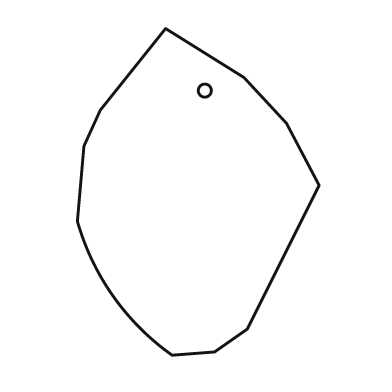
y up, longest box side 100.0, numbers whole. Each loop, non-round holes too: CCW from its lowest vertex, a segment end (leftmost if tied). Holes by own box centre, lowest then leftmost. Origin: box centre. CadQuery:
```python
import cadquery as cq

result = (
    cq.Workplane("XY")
    .moveTo(-8.0, -50.0)
    .lineTo(5.0, -49.0)
    .lineTo(15.0, -42.0)
    .lineTo(37.0, 2.0)
    .lineTo(27.0, 21.0)
    .lineTo(14.0, 35.0)
    .lineTo(-10.0, 50.0)
    .lineTo(-30.0, 25.0)
    .lineTo(-35.0, 14.0)
    .lineTo(-37.0, -9.0)
    .threePointArc((-26.0, -32.0), (-8.0, -50.0))
    .close()
    .moveTo(2.0, 31.0)
    .circle(2.0)
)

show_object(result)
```